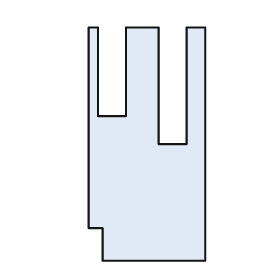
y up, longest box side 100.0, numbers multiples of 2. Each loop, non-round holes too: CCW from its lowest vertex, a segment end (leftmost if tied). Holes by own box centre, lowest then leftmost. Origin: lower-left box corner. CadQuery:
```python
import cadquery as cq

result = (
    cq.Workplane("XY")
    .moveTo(6.0, 0.0)
    .lineTo(50.0, 0.0)
    .lineTo(50.0, 100.0)
    .lineTo(42.0, 100.0)
    .lineTo(42.0, 50.0)
    .lineTo(30.0, 50.0)
    .lineTo(30.0, 100.0)
    .lineTo(16.0, 100.0)
    .lineTo(16.0, 62.0)
    .lineTo(4.0, 62.0)
    .lineTo(4.0, 100.0)
    .lineTo(0.0, 100.0)
    .lineTo(0.0, 14.0)
    .lineTo(6.0, 14.0)
    .close()
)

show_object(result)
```